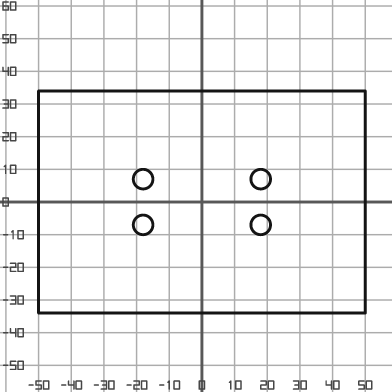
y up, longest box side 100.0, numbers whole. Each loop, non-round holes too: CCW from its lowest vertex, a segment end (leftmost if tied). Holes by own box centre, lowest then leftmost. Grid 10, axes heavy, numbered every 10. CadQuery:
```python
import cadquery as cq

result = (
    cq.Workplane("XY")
    .moveTo(-50.0, -34.0)
    .lineTo(50.0, -34.0)
    .lineTo(50.0, 34.0)
    .lineTo(-50.0, 34.0)
    .close()
    .moveTo(-18.0, -7.0)
    .circle(3.0)
    .moveTo(18.0, -7.0)
    .circle(3.0)
    .moveTo(-18.0, 7.0)
    .circle(3.0)
    .moveTo(18.0, 7.0)
    .circle(3.0)
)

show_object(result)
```